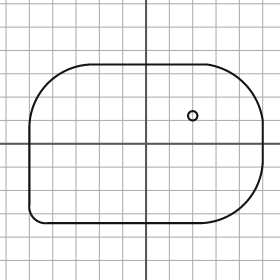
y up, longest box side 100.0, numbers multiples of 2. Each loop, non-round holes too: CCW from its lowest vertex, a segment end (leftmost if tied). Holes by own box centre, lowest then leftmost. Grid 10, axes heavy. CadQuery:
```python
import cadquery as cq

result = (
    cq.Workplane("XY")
    .moveTo(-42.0, -34.0)
    .lineTo(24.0, -34.0)
    .threePointArc((42.0, -26.0), (50.0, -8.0))
    .lineTo(50.0, 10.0)
    .threePointArc((42.0, 26.0), (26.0, 34.0))
    .lineTo(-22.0, 34.0)
    .threePointArc((-42.0, 26.0), (-50.0, 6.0))
    .lineTo(-50.0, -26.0)
    .threePointArc((-48.0, -32.0), (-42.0, -34.0))
    .close()
    .moveTo(20.0, 12.0)
    .circle(2.0)
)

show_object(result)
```